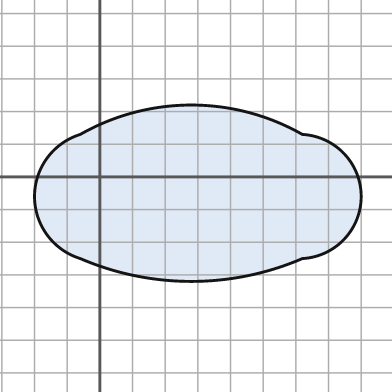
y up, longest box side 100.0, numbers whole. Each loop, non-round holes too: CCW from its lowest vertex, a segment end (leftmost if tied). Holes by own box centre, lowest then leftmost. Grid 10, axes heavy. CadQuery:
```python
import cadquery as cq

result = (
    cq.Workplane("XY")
    .moveTo(-6.0, -25.0)
    .threePointArc((28.0, -32.0), (62.0, -25.0))
    .threePointArc((80.0, -6.0), (62.0, 13.0))
    .threePointArc((28.0, 22.0), (-6.0, 13.0))
    .threePointArc((-20.0, -6.0), (-6.0, -25.0))
    .close()
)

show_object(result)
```